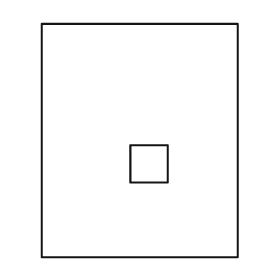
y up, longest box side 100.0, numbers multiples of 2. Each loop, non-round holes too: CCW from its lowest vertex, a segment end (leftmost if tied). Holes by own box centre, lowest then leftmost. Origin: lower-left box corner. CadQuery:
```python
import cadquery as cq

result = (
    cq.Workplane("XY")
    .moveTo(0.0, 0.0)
    .lineTo(84.0, 0.0)
    .lineTo(84.0, 100.0)
    .lineTo(0.0, 100.0)
    .close()
    .moveTo(38.0, 32.0)
    .lineTo(54.0, 32.0)
    .lineTo(54.0, 48.0)
    .lineTo(38.0, 48.0)
    .close()
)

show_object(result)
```